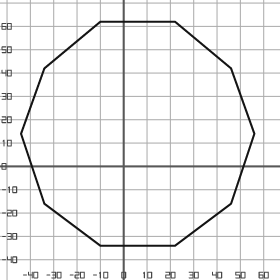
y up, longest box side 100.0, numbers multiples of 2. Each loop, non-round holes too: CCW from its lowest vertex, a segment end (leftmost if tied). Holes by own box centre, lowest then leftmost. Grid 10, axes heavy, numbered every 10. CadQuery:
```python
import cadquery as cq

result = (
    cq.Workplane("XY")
    .moveTo(-10.0, -34.0)
    .lineTo(22.0, -34.0)
    .lineTo(46.0, -16.0)
    .lineTo(56.0, 14.0)
    .lineTo(46.0, 42.0)
    .lineTo(22.0, 62.0)
    .lineTo(-10.0, 62.0)
    .lineTo(-34.0, 42.0)
    .lineTo(-44.0, 14.0)
    .lineTo(-34.0, -16.0)
    .close()
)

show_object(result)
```